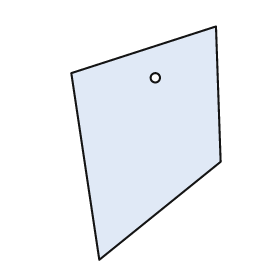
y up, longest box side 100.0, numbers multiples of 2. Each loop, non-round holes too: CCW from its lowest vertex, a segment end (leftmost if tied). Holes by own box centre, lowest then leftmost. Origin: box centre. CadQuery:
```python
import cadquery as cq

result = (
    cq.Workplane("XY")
    .moveTo(-20.0, -50.0)
    .lineTo(32.0, -8.0)
    .lineTo(30.0, 50.0)
    .lineTo(-32.0, 30.0)
    .close()
    .moveTo(4.0, 28.0)
    .circle(2.0)
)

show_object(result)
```